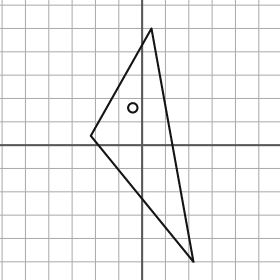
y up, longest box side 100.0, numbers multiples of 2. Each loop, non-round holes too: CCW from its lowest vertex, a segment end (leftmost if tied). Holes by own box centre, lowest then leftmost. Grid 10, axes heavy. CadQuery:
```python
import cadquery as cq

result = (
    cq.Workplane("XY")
    .moveTo(22.0, -50.0)
    .lineTo(4.0, 50.0)
    .lineTo(-22.0, 4.0)
    .close()
    .moveTo(-4.0, 16.0)
    .circle(2.0)
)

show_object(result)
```